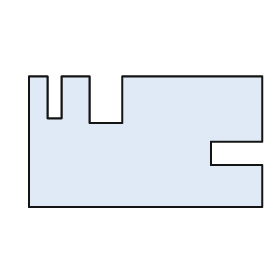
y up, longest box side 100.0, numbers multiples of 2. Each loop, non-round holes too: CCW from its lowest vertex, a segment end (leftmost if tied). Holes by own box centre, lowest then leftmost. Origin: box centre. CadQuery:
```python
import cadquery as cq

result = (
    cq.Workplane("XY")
    .moveTo(-50.0, -28.0)
    .lineTo(50.0, -28.0)
    .lineTo(50.0, -10.0)
    .lineTo(28.0, -10.0)
    .lineTo(28.0, 0.0)
    .lineTo(50.0, 0.0)
    .lineTo(50.0, 28.0)
    .lineTo(-10.0, 28.0)
    .lineTo(-10.0, 8.0)
    .lineTo(-24.0, 8.0)
    .lineTo(-24.0, 28.0)
    .lineTo(-36.0, 28.0)
    .lineTo(-36.0, 10.0)
    .lineTo(-42.0, 10.0)
    .lineTo(-42.0, 28.0)
    .lineTo(-50.0, 28.0)
    .close()
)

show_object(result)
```